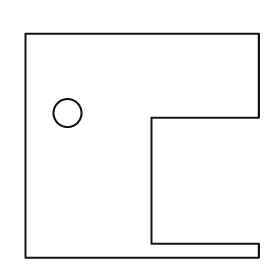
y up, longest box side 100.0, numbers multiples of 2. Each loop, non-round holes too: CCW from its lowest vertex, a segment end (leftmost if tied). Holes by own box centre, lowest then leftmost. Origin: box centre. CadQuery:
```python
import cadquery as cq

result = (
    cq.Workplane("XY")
    .moveTo(-50.0, -48.0)
    .lineTo(50.0, -48.0)
    .lineTo(50.0, -42.0)
    .lineTo(4.0, -42.0)
    .lineTo(4.0, 12.0)
    .lineTo(50.0, 12.0)
    .lineTo(50.0, 48.0)
    .lineTo(-50.0, 48.0)
    .close()
    .moveTo(-32.0, 14.0)
    .circle(6.0)
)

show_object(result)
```